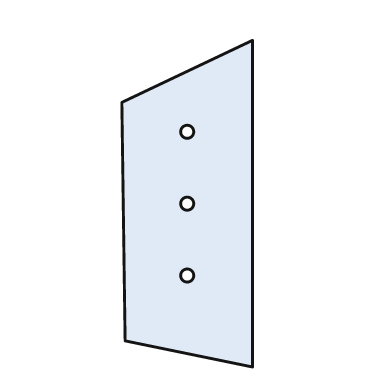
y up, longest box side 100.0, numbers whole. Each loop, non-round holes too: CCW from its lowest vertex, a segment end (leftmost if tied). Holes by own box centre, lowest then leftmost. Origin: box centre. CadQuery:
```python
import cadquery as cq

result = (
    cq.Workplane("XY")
    .moveTo(20.0, -50.0)
    .lineTo(20.0, 50.0)
    .lineTo(-20.0, 31.0)
    .lineTo(-19.0, -42.0)
    .close()
    .moveTo(0.0, -22.0)
    .circle(2.0)
    .moveTo(0.0, 0.0)
    .circle(2.0)
    .moveTo(0.0, 22.0)
    .circle(2.0)
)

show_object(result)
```